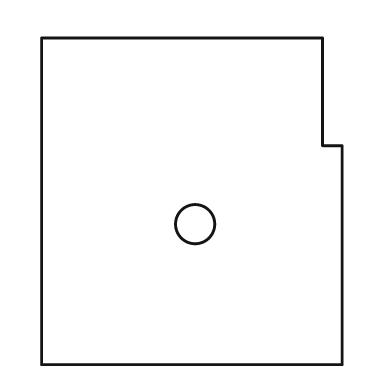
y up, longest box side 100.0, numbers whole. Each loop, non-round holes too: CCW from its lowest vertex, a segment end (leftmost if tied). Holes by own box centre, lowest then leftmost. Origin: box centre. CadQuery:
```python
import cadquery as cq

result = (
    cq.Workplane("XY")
    .moveTo(-46.0, -50.0)
    .lineTo(46.0, -50.0)
    .lineTo(46.0, 17.0)
    .lineTo(40.0, 17.0)
    .lineTo(40.0, 50.0)
    .lineTo(-46.0, 50.0)
    .close()
    .moveTo(1.0, -7.0)
    .circle(6.0)
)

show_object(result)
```